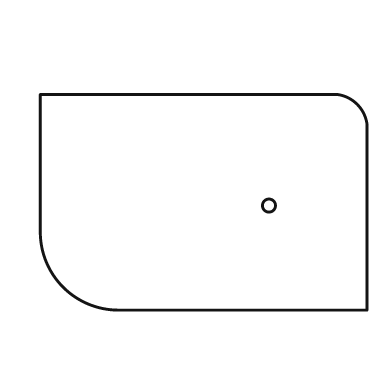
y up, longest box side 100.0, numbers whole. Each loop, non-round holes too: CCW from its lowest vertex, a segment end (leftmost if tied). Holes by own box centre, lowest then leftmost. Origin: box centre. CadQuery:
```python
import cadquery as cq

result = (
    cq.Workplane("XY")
    .moveTo(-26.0, -33.0)
    .lineTo(50.0, -33.0)
    .lineTo(50.0, 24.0)
    .threePointArc((47.0, 30.0), (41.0, 33.0))
    .lineTo(-50.0, 33.0)
    .lineTo(-50.0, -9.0)
    .threePointArc((-43.0, -26.0), (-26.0, -33.0))
    .close()
    .moveTo(20.0, -1.0)
    .circle(2.0)
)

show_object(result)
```